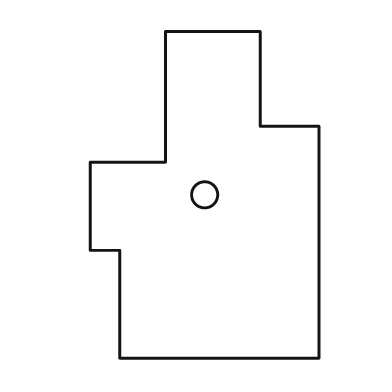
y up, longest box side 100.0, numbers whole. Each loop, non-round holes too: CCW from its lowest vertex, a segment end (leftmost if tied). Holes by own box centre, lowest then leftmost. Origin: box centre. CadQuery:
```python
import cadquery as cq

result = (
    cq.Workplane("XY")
    .moveTo(-26.0, -50.0)
    .lineTo(35.0, -50.0)
    .lineTo(35.0, 21.0)
    .lineTo(17.0, 21.0)
    .lineTo(17.0, 50.0)
    .lineTo(-12.0, 50.0)
    .lineTo(-12.0, 10.0)
    .lineTo(-35.0, 10.0)
    .lineTo(-35.0, -17.0)
    .lineTo(-26.0, -17.0)
    .close()
    .moveTo(0.0, 0.0)
    .circle(4.0)
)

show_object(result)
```